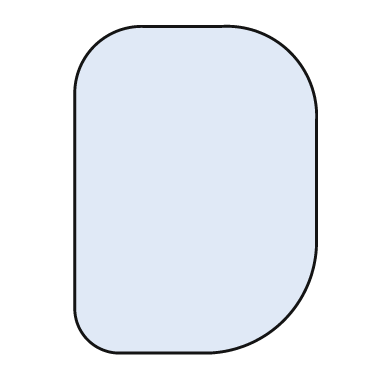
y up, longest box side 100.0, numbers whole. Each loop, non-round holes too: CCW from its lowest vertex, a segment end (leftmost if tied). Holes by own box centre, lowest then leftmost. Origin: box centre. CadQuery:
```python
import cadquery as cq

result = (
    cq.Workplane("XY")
    .moveTo(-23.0, -50.0)
    .lineTo(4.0, -50.0)
    .threePointArc((27.0, -40.0), (37.0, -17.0))
    .lineTo(37.0, 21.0)
    .threePointArc((29.0, 42.0), (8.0, 50.0))
    .lineTo(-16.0, 50.0)
    .threePointArc((-31.0, 44.0), (-37.0, 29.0))
    .lineTo(-37.0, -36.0)
    .threePointArc((-33.0, -46.0), (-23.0, -50.0))
    .close()
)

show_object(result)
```